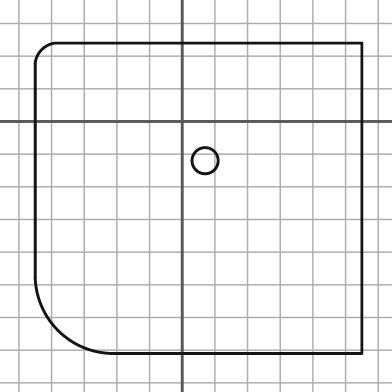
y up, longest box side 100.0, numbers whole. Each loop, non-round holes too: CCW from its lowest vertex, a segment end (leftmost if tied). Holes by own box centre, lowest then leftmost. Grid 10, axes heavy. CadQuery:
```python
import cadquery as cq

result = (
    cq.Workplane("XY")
    .moveTo(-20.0, -71.0)
    .lineTo(55.0, -71.0)
    .lineTo(55.0, 24.0)
    .lineTo(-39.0, 24.0)
    .threePointArc((-43.0, 22.0), (-45.0, 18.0))
    .lineTo(-45.0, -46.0)
    .threePointArc((-38.0, -64.0), (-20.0, -71.0))
    .close()
    .moveTo(7.0, -12.0)
    .circle(4.0)
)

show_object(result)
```